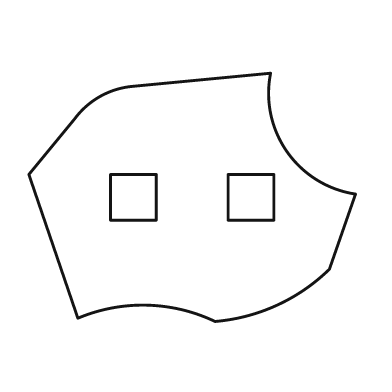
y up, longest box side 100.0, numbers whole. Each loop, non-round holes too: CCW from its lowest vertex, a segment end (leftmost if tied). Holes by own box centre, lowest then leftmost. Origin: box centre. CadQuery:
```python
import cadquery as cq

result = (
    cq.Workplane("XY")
    .moveTo(7.0, -38.0)
    .threePointArc((26.0, -33.0), (42.0, -22.0))
    .lineTo(50.0, 1.0)
    .threePointArc((29.0, 14.0), (24.0, 38.0))
    .lineTo(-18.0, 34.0)
    .threePointArc((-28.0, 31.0), (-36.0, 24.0))
    .lineTo(-50.0, 7.0)
    .lineTo(-35.0, -37.0)
    .threePointArc((-14.0, -33.0), (7.0, -38.0))
    .close()
    .moveTo(-25.0, -7.0)
    .lineTo(-11.0, -7.0)
    .lineTo(-11.0, 7.0)
    .lineTo(-25.0, 7.0)
    .close()
    .moveTo(11.0, -7.0)
    .lineTo(25.0, -7.0)
    .lineTo(25.0, 7.0)
    .lineTo(11.0, 7.0)
    .close()
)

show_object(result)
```